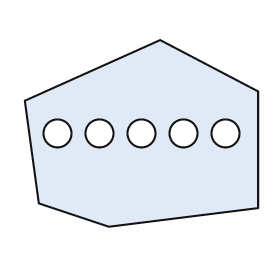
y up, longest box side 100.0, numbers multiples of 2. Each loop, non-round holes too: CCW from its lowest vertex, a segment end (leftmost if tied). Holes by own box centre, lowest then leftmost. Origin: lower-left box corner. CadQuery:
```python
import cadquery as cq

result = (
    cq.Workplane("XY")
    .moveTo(36.0, 0.0)
    .lineTo(100.0, 8.0)
    .lineTo(100.0, 58.0)
    .lineTo(58.0, 80.0)
    .lineTo(0.0, 54.0)
    .lineTo(6.0, 10.0)
    .close()
    .moveTo(14.0, 40.0)
    .circle(6.0)
    .moveTo(32.0, 40.0)
    .circle(6.0)
    .moveTo(50.0, 40.0)
    .circle(6.0)
    .moveTo(68.0, 40.0)
    .circle(6.0)
    .moveTo(86.0, 40.0)
    .circle(6.0)
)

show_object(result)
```